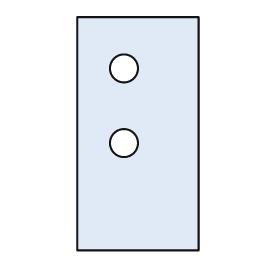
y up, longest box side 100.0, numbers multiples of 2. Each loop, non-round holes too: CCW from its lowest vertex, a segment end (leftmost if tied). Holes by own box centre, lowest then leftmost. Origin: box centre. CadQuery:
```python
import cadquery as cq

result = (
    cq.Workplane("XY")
    .moveTo(-26.0, -50.0)
    .lineTo(26.0, -50.0)
    .lineTo(26.0, 50.0)
    .lineTo(-26.0, 50.0)
    .close()
    .moveTo(-6.0, -4.0)
    .circle(6.0)
    .moveTo(-6.0, 28.0)
    .circle(6.0)
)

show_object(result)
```